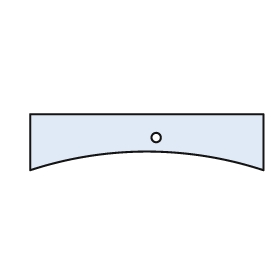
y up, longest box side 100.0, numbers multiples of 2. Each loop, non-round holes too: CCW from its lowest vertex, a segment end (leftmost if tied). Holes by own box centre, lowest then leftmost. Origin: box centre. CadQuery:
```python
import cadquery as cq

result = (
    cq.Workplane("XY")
    .moveTo(-50.0, -12.0)
    .threePointArc((0.0, -4.0), (50.0, -12.0))
    .lineTo(50.0, 12.0)
    .lineTo(-50.0, 12.0)
    .close()
    .moveTo(4.0, 2.0)
    .circle(2.0)
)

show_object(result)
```